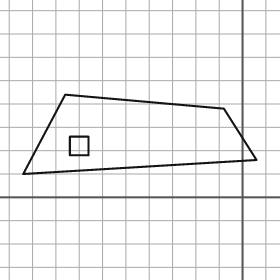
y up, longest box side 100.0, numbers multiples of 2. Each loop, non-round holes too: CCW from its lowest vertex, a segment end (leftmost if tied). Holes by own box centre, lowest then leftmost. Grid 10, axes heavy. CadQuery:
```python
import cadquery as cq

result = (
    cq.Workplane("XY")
    .moveTo(-94.0, 10.0)
    .lineTo(6.0, 16.0)
    .lineTo(-8.0, 38.0)
    .lineTo(-76.0, 44.0)
    .close()
    .moveTo(-74.0, 18.0)
    .lineTo(-66.0, 18.0)
    .lineTo(-66.0, 26.0)
    .lineTo(-74.0, 26.0)
    .close()
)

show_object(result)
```